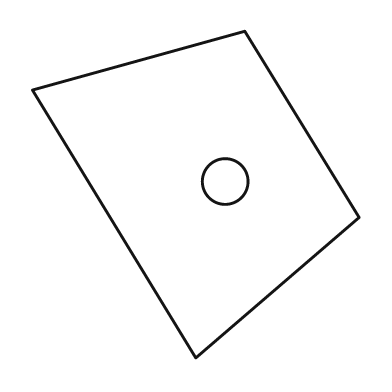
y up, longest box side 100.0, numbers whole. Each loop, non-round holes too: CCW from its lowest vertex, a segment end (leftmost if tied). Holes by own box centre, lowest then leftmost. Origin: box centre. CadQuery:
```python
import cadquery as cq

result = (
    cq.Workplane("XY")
    .moveTo(0.0, -50.0)
    .lineTo(50.0, -7.0)
    .lineTo(15.0, 50.0)
    .lineTo(-50.0, 32.0)
    .close()
    .moveTo(9.0, 4.0)
    .circle(7.0)
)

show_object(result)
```